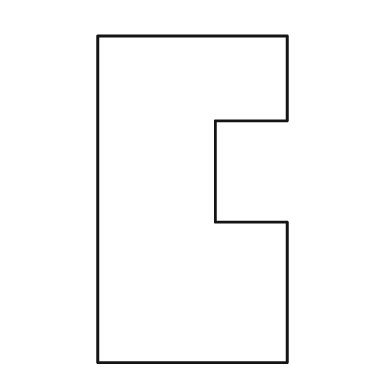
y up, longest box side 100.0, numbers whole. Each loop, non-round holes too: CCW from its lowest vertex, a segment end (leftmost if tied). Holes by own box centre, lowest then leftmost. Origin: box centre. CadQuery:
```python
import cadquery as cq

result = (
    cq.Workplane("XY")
    .moveTo(-29.0, -50.0)
    .lineTo(29.0, -50.0)
    .lineTo(29.0, -7.0)
    .lineTo(7.0, -7.0)
    .lineTo(7.0, 24.0)
    .lineTo(29.0, 24.0)
    .lineTo(29.0, 50.0)
    .lineTo(-29.0, 50.0)
    .close()
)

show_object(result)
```